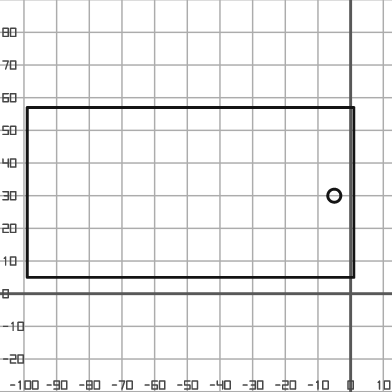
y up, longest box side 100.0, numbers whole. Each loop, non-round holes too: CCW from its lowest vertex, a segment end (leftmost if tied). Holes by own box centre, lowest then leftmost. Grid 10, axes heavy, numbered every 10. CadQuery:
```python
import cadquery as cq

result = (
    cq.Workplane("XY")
    .moveTo(-99.0, 5.0)
    .lineTo(1.0, 5.0)
    .lineTo(1.0, 57.0)
    .lineTo(-99.0, 57.0)
    .close()
    .moveTo(-5.0, 30.0)
    .circle(2.0)
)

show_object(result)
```